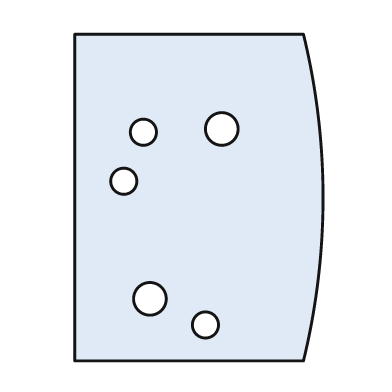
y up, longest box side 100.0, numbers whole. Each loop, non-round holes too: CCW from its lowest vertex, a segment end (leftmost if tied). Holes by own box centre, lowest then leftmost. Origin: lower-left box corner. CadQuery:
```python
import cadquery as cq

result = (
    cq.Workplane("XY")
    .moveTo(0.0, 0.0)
    .lineTo(70.0, 0.0)
    .threePointArc((76.0, 50.0), (70.0, 100.0))
    .lineTo(0.0, 100.0)
    .close()
    .moveTo(40.0, 11.0)
    .circle(4.0)
    .moveTo(23.0, 19.0)
    .circle(5.0)
    .moveTo(15.0, 55.0)
    .circle(4.0)
    .moveTo(21.0, 70.0)
    .circle(4.0)
    .moveTo(45.0, 71.0)
    .circle(5.0)
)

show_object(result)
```